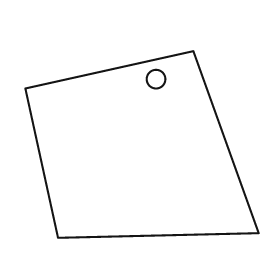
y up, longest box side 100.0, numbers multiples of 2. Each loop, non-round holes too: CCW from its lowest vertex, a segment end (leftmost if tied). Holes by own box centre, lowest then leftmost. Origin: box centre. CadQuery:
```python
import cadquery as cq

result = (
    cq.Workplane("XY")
    .moveTo(-36.0, -40.0)
    .lineTo(50.0, -38.0)
    .lineTo(22.0, 40.0)
    .lineTo(-50.0, 24.0)
    .close()
    .moveTo(6.0, 28.0)
    .circle(4.0)
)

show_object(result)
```